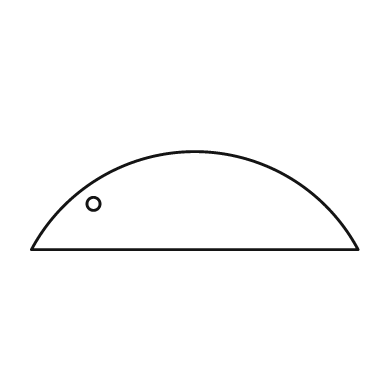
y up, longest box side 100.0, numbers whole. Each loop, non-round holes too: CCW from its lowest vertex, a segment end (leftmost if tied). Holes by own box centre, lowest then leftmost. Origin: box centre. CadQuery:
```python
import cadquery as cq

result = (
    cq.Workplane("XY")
    .moveTo(-50.0, -15.0)
    .lineTo(50.0, -15.0)
    .threePointArc((0.0, 15.0), (-50.0, -15.0))
    .close()
    .moveTo(-31.0, -1.0)
    .circle(2.0)
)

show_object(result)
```